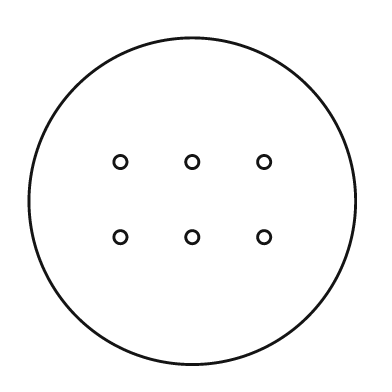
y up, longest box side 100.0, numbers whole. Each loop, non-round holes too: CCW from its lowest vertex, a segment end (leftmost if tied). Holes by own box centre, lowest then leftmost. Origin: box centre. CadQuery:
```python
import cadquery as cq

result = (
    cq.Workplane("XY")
    .moveTo(0.0, 0.0)
    .circle(50.0)
    .moveTo(-22.0, -11.0)
    .circle(2.0)
    .moveTo(0.0, -11.0)
    .circle(2.0)
    .moveTo(22.0, -11.0)
    .circle(2.0)
    .moveTo(-22.0, 12.0)
    .circle(2.0)
    .moveTo(0.0, 12.0)
    .circle(2.0)
    .moveTo(22.0, 12.0)
    .circle(2.0)
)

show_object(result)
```